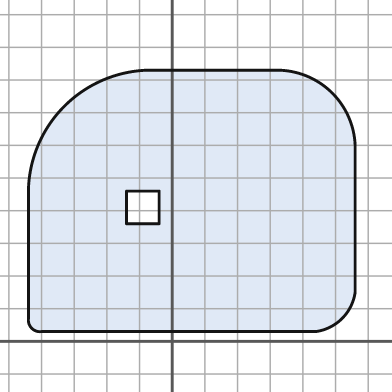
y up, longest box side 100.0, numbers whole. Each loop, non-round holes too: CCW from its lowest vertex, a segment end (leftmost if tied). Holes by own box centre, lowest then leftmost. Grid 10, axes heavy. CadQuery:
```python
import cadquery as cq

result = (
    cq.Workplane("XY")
    .moveTo(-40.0, 3.0)
    .lineTo(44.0, 3.0)
    .threePointArc((52.0, 7.0), (56.0, 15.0))
    .lineTo(56.0, 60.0)
    .threePointArc((49.0, 76.0), (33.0, 83.0))
    .lineTo(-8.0, 83.0)
    .threePointArc((-33.0, 72.0), (-44.0, 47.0))
    .lineTo(-44.0, 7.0)
    .threePointArc((-43.0, 4.0), (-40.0, 3.0))
    .close()
    .moveTo(-14.0, 36.0)
    .lineTo(-4.0, 36.0)
    .lineTo(-4.0, 46.0)
    .lineTo(-14.0, 46.0)
    .close()
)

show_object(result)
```